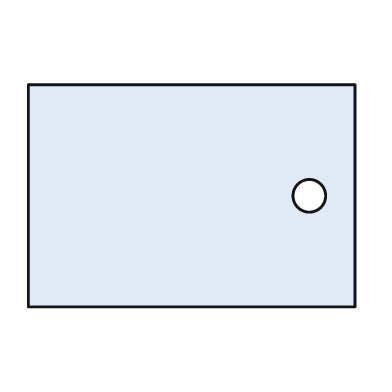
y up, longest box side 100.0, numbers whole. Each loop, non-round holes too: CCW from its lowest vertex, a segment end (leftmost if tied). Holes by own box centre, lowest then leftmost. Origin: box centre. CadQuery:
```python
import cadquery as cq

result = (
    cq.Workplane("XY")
    .moveTo(-50.0, -34.0)
    .lineTo(50.0, -34.0)
    .lineTo(50.0, 34.0)
    .lineTo(-50.0, 34.0)
    .close()
    .moveTo(36.0, 0.0)
    .circle(5.0)
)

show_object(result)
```